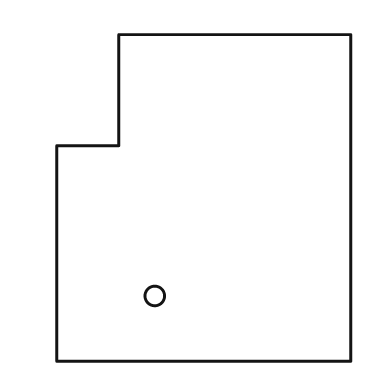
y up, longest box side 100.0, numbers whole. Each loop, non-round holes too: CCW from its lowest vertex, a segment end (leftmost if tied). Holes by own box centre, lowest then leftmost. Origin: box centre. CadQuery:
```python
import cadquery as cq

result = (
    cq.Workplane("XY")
    .moveTo(-45.0, -50.0)
    .lineTo(45.0, -50.0)
    .lineTo(45.0, 50.0)
    .lineTo(-26.0, 50.0)
    .lineTo(-26.0, 16.0)
    .lineTo(-45.0, 16.0)
    .close()
    .moveTo(-15.0, -30.0)
    .circle(3.0)
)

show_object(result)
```